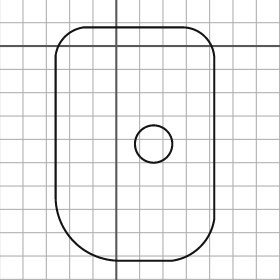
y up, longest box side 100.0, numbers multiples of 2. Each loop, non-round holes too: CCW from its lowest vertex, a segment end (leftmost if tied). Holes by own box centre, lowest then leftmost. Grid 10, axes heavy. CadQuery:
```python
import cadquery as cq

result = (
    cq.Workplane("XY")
    .moveTo(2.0, -92.0)
    .lineTo(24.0, -92.0)
    .threePointArc((36.0, -86.0), (42.0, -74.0))
    .lineTo(42.0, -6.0)
    .threePointArc((38.0, 4.0), (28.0, 8.0))
    .lineTo(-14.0, 8.0)
    .threePointArc((-22.0, 4.0), (-26.0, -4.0))
    .lineTo(-26.0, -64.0)
    .threePointArc((-18.0, -84.0), (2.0, -92.0))
    .close()
    .moveTo(16.0, -42.0)
    .circle(8.0)
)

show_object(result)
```